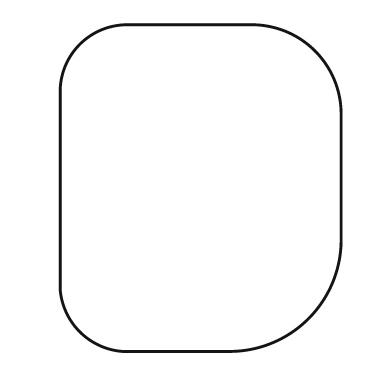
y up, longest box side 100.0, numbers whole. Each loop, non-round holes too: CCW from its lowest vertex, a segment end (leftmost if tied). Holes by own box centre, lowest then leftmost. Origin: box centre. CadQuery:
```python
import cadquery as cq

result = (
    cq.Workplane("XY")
    .moveTo(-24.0, -50.0)
    .lineTo(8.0, -50.0)
    .threePointArc((33.0, -40.0), (43.0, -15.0))
    .lineTo(43.0, 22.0)
    .threePointArc((35.0, 42.0), (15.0, 50.0))
    .lineTo(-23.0, 50.0)
    .threePointArc((-37.0, 44.0), (-43.0, 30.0))
    .lineTo(-43.0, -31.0)
    .threePointArc((-37.0, -44.0), (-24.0, -50.0))
    .close()
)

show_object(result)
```